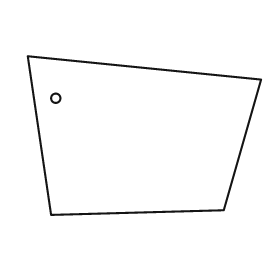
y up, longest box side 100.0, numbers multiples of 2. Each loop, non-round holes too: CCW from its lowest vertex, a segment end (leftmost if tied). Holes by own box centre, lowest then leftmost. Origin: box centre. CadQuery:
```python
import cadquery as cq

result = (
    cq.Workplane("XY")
    .moveTo(-40.0, -34.0)
    .lineTo(34.0, -32.0)
    .lineTo(50.0, 24.0)
    .lineTo(-50.0, 34.0)
    .close()
    .moveTo(-38.0, 16.0)
    .circle(2.0)
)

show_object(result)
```